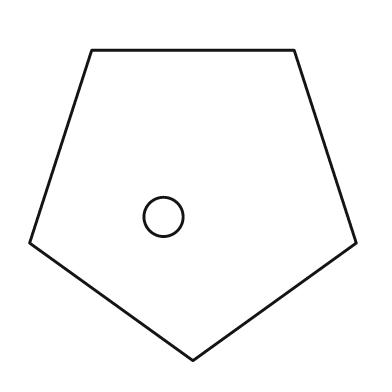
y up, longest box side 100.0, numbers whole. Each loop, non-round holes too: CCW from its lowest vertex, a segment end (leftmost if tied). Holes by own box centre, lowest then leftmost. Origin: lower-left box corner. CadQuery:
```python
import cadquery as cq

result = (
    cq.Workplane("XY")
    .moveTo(50.0, 0.0)
    .lineTo(100.0, 36.0)
    .lineTo(81.0, 95.0)
    .lineTo(19.0, 95.0)
    .lineTo(0.0, 36.0)
    .close()
    .moveTo(41.0, 44.0)
    .circle(6.0)
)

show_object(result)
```